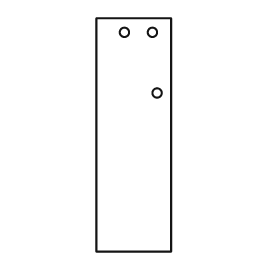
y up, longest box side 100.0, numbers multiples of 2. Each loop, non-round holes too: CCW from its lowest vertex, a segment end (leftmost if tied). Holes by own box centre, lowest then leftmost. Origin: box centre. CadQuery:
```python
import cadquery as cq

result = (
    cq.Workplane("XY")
    .moveTo(-16.0, -50.0)
    .lineTo(16.0, -50.0)
    .lineTo(16.0, 50.0)
    .lineTo(-16.0, 50.0)
    .close()
    .moveTo(10.0, 18.0)
    .circle(2.0)
    .moveTo(-4.0, 44.0)
    .circle(2.0)
    .moveTo(8.0, 44.0)
    .circle(2.0)
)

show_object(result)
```